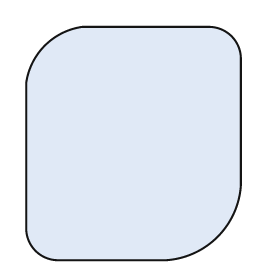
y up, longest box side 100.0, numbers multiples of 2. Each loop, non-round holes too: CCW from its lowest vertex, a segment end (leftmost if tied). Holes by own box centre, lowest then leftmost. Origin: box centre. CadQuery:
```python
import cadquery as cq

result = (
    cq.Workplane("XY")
    .moveTo(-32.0, -50.0)
    .lineTo(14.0, -50.0)
    .threePointArc((36.0, -40.0), (46.0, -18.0))
    .lineTo(46.0, 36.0)
    .threePointArc((42.0, 46.0), (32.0, 50.0))
    .lineTo(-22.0, 50.0)
    .threePointArc((-38.0, 42.0), (-46.0, 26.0))
    .lineTo(-46.0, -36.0)
    .threePointArc((-42.0, -46.0), (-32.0, -50.0))
    .close()
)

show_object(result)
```